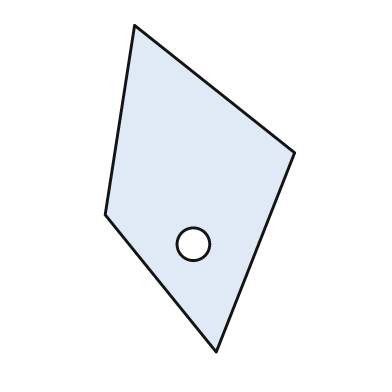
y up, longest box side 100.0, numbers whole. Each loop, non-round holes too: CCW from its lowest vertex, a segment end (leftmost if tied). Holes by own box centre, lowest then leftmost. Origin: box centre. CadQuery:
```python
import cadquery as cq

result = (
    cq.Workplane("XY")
    .moveTo(5.0, -50.0)
    .lineTo(29.0, 11.0)
    .lineTo(-20.0, 50.0)
    .lineTo(-29.0, -8.0)
    .close()
    .moveTo(-2.0, -17.0)
    .circle(5.0)
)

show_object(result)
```